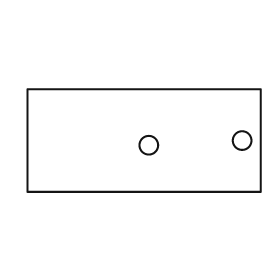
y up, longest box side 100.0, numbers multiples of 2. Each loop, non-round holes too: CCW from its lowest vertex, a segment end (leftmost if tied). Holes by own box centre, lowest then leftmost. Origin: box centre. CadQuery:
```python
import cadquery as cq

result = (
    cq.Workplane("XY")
    .moveTo(-50.0, -22.0)
    .lineTo(50.0, -22.0)
    .lineTo(50.0, 22.0)
    .lineTo(-50.0, 22.0)
    .close()
    .moveTo(2.0, -2.0)
    .circle(4.0)
    .moveTo(42.0, 0.0)
    .circle(4.0)
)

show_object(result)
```